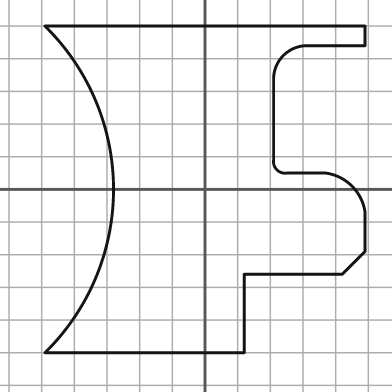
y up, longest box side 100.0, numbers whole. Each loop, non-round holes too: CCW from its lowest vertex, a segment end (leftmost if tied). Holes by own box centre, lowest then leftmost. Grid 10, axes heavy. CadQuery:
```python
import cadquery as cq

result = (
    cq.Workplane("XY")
    .moveTo(-49.0, -50.0)
    .lineTo(12.0, -50.0)
    .lineTo(12.0, -26.0)
    .lineTo(42.0, -26.0)
    .lineTo(49.0, -19.0)
    .lineTo(49.0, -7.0)
    .threePointArc((45.0, 1.0), (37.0, 5.0))
    .lineTo(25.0, 5.0)
    .threePointArc((22.0, 6.0), (21.0, 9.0))
    .lineTo(21.0, 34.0)
    .threePointArc((24.0, 41.0), (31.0, 44.0))
    .lineTo(49.0, 44.0)
    .lineTo(49.0, 50.0)
    .lineTo(-49.0, 50.0)
    .threePointArc((-28.0, 0.0), (-49.0, -50.0))
    .close()
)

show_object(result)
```